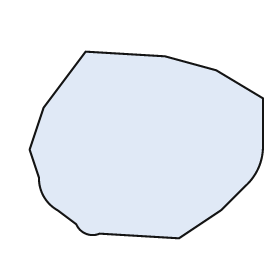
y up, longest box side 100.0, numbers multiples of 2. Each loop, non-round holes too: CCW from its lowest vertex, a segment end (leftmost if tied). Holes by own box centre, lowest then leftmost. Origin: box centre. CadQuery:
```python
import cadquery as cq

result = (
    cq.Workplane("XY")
    .moveTo(14.0, -40.0)
    .lineTo(32.0, -28.0)
    .lineTo(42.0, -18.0)
    .threePointArc((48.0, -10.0), (50.0, 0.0))
    .lineTo(50.0, 20.0)
    .lineTo(30.0, 32.0)
    .lineTo(8.0, 38.0)
    .lineTo(-26.0, 40.0)
    .lineTo(-44.0, 16.0)
    .lineTo(-50.0, -2.0)
    .lineTo(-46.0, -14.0)
    .threePointArc((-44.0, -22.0), (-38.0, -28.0))
    .lineTo(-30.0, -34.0)
    .threePointArc((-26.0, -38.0), (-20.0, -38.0))
    .close()
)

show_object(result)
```